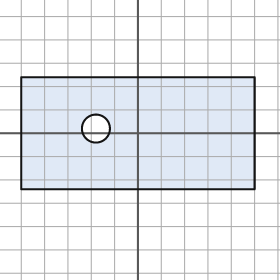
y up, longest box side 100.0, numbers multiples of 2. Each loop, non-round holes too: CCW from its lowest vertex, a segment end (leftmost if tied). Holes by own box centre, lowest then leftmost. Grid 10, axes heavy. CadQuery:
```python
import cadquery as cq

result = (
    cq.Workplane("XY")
    .moveTo(-50.0, -24.0)
    .lineTo(50.0, -24.0)
    .lineTo(50.0, 24.0)
    .lineTo(-50.0, 24.0)
    .close()
    .moveTo(-18.0, 2.0)
    .circle(6.0)
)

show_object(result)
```